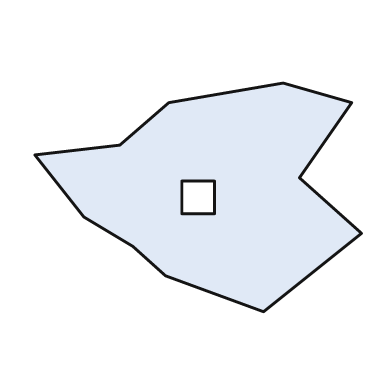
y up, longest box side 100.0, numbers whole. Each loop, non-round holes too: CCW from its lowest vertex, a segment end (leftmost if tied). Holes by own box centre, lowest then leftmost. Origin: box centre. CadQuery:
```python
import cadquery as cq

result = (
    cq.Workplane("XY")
    .moveTo(20.0, -35.0)
    .lineTo(50.0, -11.0)
    .lineTo(31.0, 6.0)
    .lineTo(47.0, 29.0)
    .lineTo(26.0, 35.0)
    .lineTo(-9.0, 29.0)
    .lineTo(-24.0, 16.0)
    .lineTo(-50.0, 13.0)
    .lineTo(-35.0, -6.0)
    .lineTo(-20.0, -15.0)
    .lineTo(-10.0, -24.0)
    .close()
    .moveTo(-5.0, -5.0)
    .lineTo(5.0, -5.0)
    .lineTo(5.0, 5.0)
    .lineTo(-5.0, 5.0)
    .close()
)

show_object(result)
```